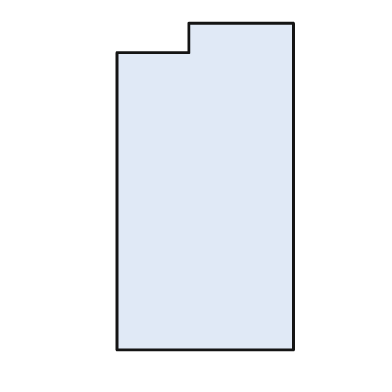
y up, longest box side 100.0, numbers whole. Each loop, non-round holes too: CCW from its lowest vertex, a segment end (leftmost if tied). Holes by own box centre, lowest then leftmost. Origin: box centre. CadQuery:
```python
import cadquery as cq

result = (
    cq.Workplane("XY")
    .moveTo(-27.0, -50.0)
    .lineTo(27.0, -50.0)
    .lineTo(27.0, 50.0)
    .lineTo(-5.0, 50.0)
    .lineTo(-5.0, 41.0)
    .lineTo(-27.0, 41.0)
    .close()
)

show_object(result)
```